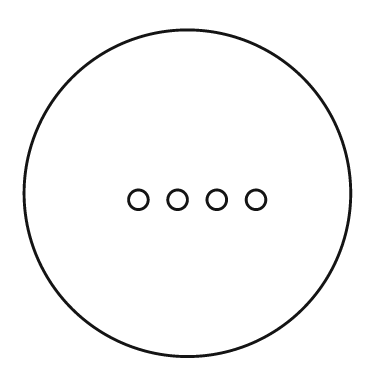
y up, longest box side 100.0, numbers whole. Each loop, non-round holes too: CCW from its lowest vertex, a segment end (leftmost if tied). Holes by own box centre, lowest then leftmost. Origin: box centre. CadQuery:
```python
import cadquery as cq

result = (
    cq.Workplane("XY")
    .moveTo(0.0, 0.0)
    .circle(50.0)
    .moveTo(-15.0, -2.0)
    .circle(3.0)
    .moveTo(-3.0, -2.0)
    .circle(3.0)
    .moveTo(9.0, -2.0)
    .circle(3.0)
    .moveTo(21.0, -2.0)
    .circle(3.0)
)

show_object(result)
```